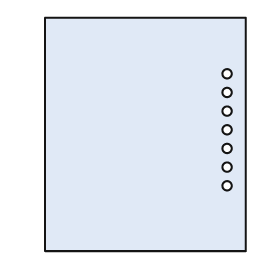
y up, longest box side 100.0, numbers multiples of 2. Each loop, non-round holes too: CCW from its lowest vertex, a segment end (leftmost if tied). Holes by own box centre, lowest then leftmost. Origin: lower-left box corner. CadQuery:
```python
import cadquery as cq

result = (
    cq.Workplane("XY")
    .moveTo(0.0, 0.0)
    .lineTo(86.0, 0.0)
    .lineTo(86.0, 100.0)
    .lineTo(0.0, 100.0)
    .close()
    .moveTo(78.0, 28.0)
    .circle(2.0)
    .moveTo(78.0, 36.0)
    .circle(2.0)
    .moveTo(78.0, 44.0)
    .circle(2.0)
    .moveTo(78.0, 52.0)
    .circle(2.0)
    .moveTo(78.0, 60.0)
    .circle(2.0)
    .moveTo(78.0, 68.0)
    .circle(2.0)
    .moveTo(78.0, 76.0)
    .circle(2.0)
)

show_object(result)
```